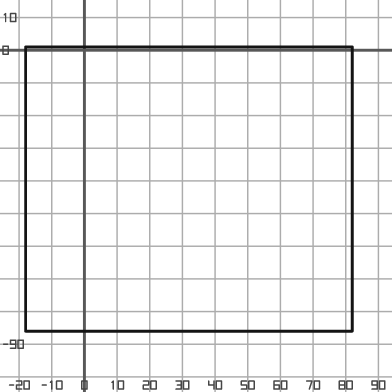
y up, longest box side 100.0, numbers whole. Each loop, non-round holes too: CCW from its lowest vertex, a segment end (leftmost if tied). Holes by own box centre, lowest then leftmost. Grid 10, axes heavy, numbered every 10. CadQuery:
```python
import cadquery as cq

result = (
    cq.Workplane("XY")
    .moveTo(-18.0, -86.0)
    .lineTo(82.0, -86.0)
    .lineTo(82.0, 1.0)
    .lineTo(-18.0, 1.0)
    .close()
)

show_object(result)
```